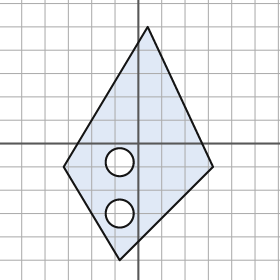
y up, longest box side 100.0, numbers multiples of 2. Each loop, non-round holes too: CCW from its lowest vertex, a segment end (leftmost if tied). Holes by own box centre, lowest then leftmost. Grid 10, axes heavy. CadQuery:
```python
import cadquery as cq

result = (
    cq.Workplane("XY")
    .moveTo(-8.0, -50.0)
    .lineTo(32.0, -10.0)
    .lineTo(4.0, 50.0)
    .lineTo(-32.0, -10.0)
    .close()
    .moveTo(-8.0, -30.0)
    .circle(6.0)
    .moveTo(-8.0, -8.0)
    .circle(6.0)
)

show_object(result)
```